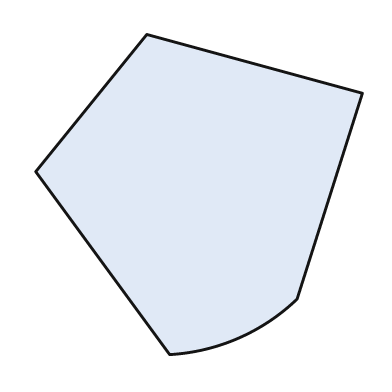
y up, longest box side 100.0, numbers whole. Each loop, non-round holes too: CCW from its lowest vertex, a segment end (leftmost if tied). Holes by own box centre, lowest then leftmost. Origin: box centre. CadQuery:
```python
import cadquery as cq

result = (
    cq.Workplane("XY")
    .moveTo(-9.0, -49.0)
    .threePointArc((12.0, -44.0), (30.0, -32.0))
    .lineTo(50.0, 31.0)
    .lineTo(-16.0, 49.0)
    .lineTo(-50.0, 7.0)
    .close()
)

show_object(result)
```